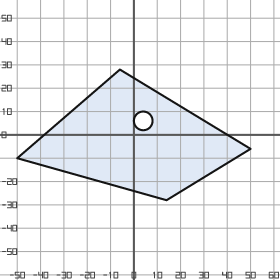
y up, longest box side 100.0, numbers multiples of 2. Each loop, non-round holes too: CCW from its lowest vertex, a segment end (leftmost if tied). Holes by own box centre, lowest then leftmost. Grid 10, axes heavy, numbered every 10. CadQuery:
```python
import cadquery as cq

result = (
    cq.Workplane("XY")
    .moveTo(14.0, -28.0)
    .lineTo(50.0, -6.0)
    .lineTo(-6.0, 28.0)
    .lineTo(-50.0, -10.0)
    .close()
    .moveTo(4.0, 6.0)
    .circle(4.0)
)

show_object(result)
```